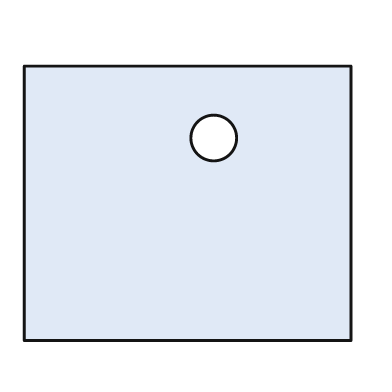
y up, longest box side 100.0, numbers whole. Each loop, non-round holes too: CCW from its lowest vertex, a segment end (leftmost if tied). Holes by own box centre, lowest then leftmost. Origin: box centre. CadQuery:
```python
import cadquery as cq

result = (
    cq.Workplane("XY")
    .moveTo(-50.0, -42.0)
    .lineTo(50.0, -42.0)
    .lineTo(50.0, 42.0)
    .lineTo(-50.0, 42.0)
    .close()
    .moveTo(8.0, 20.0)
    .circle(7.0)
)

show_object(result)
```